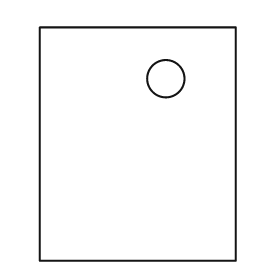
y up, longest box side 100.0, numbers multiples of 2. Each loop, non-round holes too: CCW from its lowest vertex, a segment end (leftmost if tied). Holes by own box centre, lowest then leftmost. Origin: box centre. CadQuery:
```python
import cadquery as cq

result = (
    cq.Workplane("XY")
    .moveTo(-42.0, -50.0)
    .lineTo(42.0, -50.0)
    .lineTo(42.0, 50.0)
    .lineTo(-42.0, 50.0)
    .close()
    .moveTo(12.0, 28.0)
    .circle(8.0)
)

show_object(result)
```